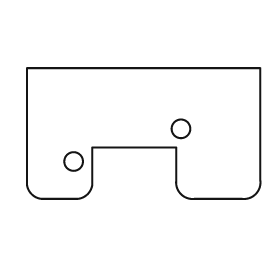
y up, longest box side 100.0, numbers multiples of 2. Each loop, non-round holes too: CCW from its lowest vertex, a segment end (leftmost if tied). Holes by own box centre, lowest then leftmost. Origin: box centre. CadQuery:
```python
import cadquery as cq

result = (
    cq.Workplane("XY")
    .moveTo(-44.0, -28.0)
    .lineTo(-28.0, -28.0)
    .threePointArc((-24.0, -26.0), (-22.0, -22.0))
    .lineTo(-22.0, -6.0)
    .lineTo(14.0, -6.0)
    .lineTo(14.0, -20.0)
    .threePointArc((16.0, -26.0), (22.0, -28.0))
    .lineTo(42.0, -28.0)
    .threePointArc((48.0, -26.0), (50.0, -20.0))
    .lineTo(50.0, 28.0)
    .lineTo(-50.0, 28.0)
    .lineTo(-50.0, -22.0)
    .threePointArc((-48.0, -26.0), (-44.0, -28.0))
    .close()
    .moveTo(-30.0, -12.0)
    .circle(4.0)
    .moveTo(16.0, 2.0)
    .circle(4.0)
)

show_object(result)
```